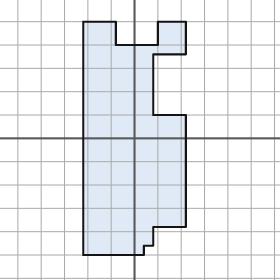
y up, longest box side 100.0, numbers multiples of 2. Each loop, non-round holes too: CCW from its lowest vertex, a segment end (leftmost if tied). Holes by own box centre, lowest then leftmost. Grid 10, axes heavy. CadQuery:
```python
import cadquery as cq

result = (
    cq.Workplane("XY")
    .moveTo(-22.0, -50.0)
    .lineTo(4.0, -50.0)
    .lineTo(4.0, -46.0)
    .lineTo(8.0, -46.0)
    .lineTo(8.0, -38.0)
    .lineTo(22.0, -38.0)
    .lineTo(22.0, 10.0)
    .lineTo(8.0, 10.0)
    .lineTo(8.0, 36.0)
    .lineTo(22.0, 36.0)
    .lineTo(22.0, 50.0)
    .lineTo(10.0, 50.0)
    .lineTo(10.0, 40.0)
    .lineTo(-8.0, 40.0)
    .lineTo(-8.0, 50.0)
    .lineTo(-22.0, 50.0)
    .close()
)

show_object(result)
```